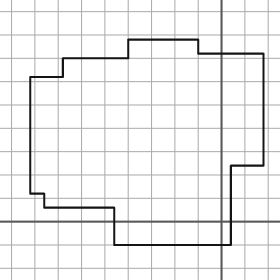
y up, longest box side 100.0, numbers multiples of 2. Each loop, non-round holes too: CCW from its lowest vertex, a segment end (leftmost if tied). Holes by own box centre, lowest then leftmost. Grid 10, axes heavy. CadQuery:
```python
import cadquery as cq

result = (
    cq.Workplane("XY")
    .moveTo(-46.0, -10.0)
    .lineTo(4.0, -10.0)
    .lineTo(4.0, 24.0)
    .lineTo(18.0, 24.0)
    .lineTo(18.0, 72.0)
    .lineTo(-10.0, 72.0)
    .lineTo(-10.0, 78.0)
    .lineTo(-40.0, 78.0)
    .lineTo(-40.0, 70.0)
    .lineTo(-68.0, 70.0)
    .lineTo(-68.0, 62.0)
    .lineTo(-82.0, 62.0)
    .lineTo(-82.0, 12.0)
    .lineTo(-76.0, 12.0)
    .lineTo(-76.0, 6.0)
    .lineTo(-46.0, 6.0)
    .close()
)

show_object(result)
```